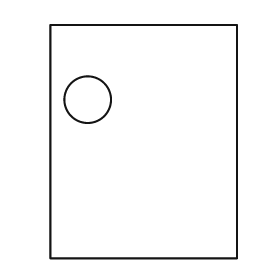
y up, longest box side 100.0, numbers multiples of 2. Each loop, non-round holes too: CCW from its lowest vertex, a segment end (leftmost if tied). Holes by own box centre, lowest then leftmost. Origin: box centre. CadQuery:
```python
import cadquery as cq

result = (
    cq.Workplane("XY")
    .moveTo(-40.0, -50.0)
    .lineTo(40.0, -50.0)
    .lineTo(40.0, 50.0)
    .lineTo(-40.0, 50.0)
    .close()
    .moveTo(-24.0, 18.0)
    .circle(10.0)
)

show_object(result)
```